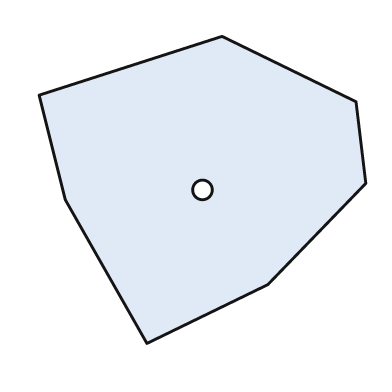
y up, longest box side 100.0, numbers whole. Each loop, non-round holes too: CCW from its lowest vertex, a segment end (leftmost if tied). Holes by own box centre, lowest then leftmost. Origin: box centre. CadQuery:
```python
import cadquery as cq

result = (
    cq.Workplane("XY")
    .moveTo(-17.0, -47.0)
    .lineTo(20.0, -29.0)
    .lineTo(50.0, 2.0)
    .lineTo(47.0, 27.0)
    .lineTo(6.0, 47.0)
    .lineTo(-50.0, 29.0)
    .lineTo(-42.0, -3.0)
    .close()
    .moveTo(0.0, 0.0)
    .circle(3.0)
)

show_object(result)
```